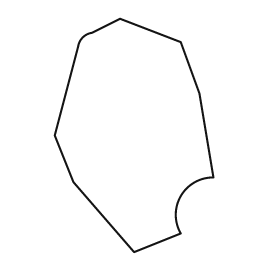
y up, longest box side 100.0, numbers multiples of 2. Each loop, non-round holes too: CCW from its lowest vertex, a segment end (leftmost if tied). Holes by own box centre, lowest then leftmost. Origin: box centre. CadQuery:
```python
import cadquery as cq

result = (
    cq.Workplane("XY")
    .moveTo(0.0, -50.0)
    .lineTo(20.0, -42.0)
    .threePointArc((20.0, -26.0), (34.0, -18.0))
    .lineTo(28.0, 18.0)
    .lineTo(20.0, 40.0)
    .lineTo(-6.0, 50.0)
    .lineTo(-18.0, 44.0)
    .threePointArc((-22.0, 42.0), (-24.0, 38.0))
    .lineTo(-34.0, 0.0)
    .lineTo(-26.0, -20.0)
    .close()
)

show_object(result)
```